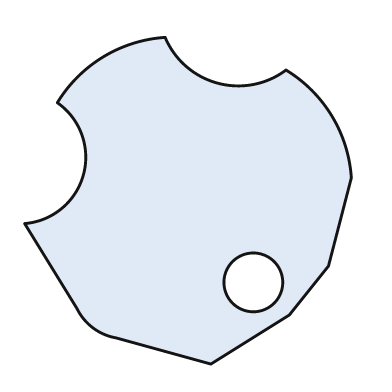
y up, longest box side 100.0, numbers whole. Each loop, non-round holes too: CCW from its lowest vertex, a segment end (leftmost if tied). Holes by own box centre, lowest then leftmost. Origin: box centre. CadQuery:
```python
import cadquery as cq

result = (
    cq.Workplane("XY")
    .moveTo(7.0, -50.0)
    .lineTo(31.0, -35.0)
    .lineTo(43.0, -20.0)
    .lineTo(50.0, 7.0)
    .threePointArc((44.0, 26.0), (30.0, 40.0))
    .threePointArc((9.0, 36.0), (-7.0, 50.0))
    .threePointArc((-26.0, 44.0), (-40.0, 30.0))
    .threePointArc((-32.0, 8.0), (-50.0, -7.0))
    .lineTo(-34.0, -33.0)
    .threePointArc((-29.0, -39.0), (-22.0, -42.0))
    .close()
    .moveTo(20.0, -25.0)
    .circle(9.0)
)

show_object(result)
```